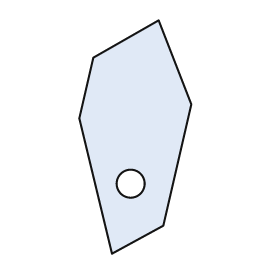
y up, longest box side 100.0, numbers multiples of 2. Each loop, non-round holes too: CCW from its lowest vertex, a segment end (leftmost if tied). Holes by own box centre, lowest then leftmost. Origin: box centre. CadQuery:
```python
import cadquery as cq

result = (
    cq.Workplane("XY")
    .moveTo(-10.0, -50.0)
    .lineTo(12.0, -38.0)
    .lineTo(24.0, 14.0)
    .lineTo(10.0, 50.0)
    .lineTo(-18.0, 34.0)
    .lineTo(-24.0, 8.0)
    .close()
    .moveTo(-2.0, -20.0)
    .circle(6.0)
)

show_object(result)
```